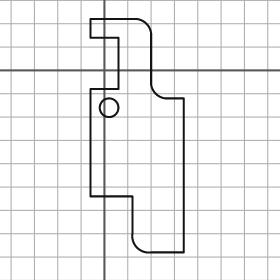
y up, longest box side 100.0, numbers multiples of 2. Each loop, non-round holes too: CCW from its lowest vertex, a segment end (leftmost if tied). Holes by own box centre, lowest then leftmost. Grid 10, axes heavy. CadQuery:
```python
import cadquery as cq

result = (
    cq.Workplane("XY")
    .moveTo(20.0, -78.0)
    .lineTo(34.0, -78.0)
    .lineTo(34.0, -12.0)
    .lineTo(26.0, -12.0)
    .threePointArc((22.0, -10.0), (20.0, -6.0))
    .lineTo(20.0, 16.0)
    .threePointArc((18.0, 20.0), (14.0, 22.0))
    .lineTo(-6.0, 22.0)
    .lineTo(-6.0, 14.0)
    .lineTo(6.0, 14.0)
    .lineTo(6.0, -8.0)
    .lineTo(-6.0, -8.0)
    .lineTo(-6.0, -54.0)
    .lineTo(12.0, -54.0)
    .lineTo(12.0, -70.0)
    .threePointArc((14.0, -76.0), (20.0, -78.0))
    .close()
    .moveTo(2.0, -16.0)
    .circle(4.0)
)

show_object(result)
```